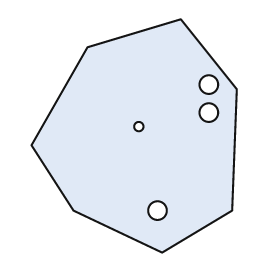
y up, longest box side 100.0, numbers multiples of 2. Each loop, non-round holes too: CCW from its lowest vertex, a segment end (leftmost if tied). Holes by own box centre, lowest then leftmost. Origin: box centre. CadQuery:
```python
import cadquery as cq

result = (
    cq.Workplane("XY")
    .moveTo(12.0, -50.0)
    .lineTo(42.0, -32.0)
    .lineTo(44.0, 20.0)
    .lineTo(20.0, 50.0)
    .lineTo(-20.0, 38.0)
    .lineTo(-44.0, -4.0)
    .lineTo(-26.0, -32.0)
    .close()
    .moveTo(10.0, -32.0)
    .circle(4.0)
    .moveTo(2.0, 4.0)
    .circle(2.0)
    .moveTo(32.0, 10.0)
    .circle(4.0)
    .moveTo(32.0, 22.0)
    .circle(4.0)
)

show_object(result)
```